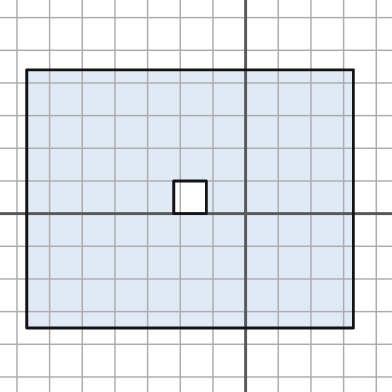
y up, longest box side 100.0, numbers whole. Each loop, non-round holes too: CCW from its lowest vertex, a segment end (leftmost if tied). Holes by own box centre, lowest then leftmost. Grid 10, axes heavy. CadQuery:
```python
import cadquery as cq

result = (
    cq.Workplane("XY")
    .moveTo(-67.0, -35.0)
    .lineTo(33.0, -35.0)
    .lineTo(33.0, 44.0)
    .lineTo(-67.0, 44.0)
    .close()
    .moveTo(-22.0, 0.0)
    .lineTo(-12.0, 0.0)
    .lineTo(-12.0, 10.0)
    .lineTo(-22.0, 10.0)
    .close()
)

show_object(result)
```